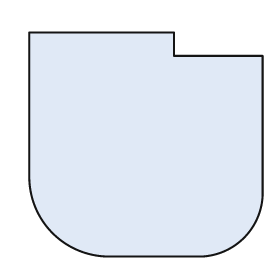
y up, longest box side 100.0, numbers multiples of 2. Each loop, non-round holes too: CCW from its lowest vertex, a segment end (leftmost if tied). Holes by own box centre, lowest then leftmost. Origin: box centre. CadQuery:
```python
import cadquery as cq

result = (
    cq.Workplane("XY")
    .moveTo(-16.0, -48.0)
    .lineTo(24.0, -48.0)
    .threePointArc((42.0, -40.0), (50.0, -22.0))
    .lineTo(50.0, 38.0)
    .lineTo(12.0, 38.0)
    .lineTo(12.0, 48.0)
    .lineTo(-50.0, 48.0)
    .lineTo(-50.0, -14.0)
    .threePointArc((-40.0, -38.0), (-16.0, -48.0))
    .close()
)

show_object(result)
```